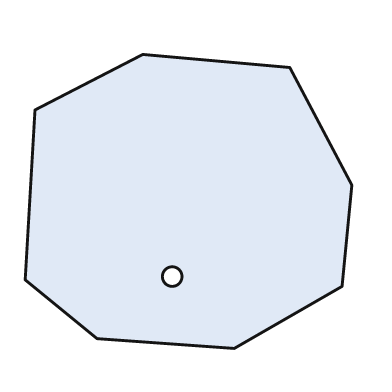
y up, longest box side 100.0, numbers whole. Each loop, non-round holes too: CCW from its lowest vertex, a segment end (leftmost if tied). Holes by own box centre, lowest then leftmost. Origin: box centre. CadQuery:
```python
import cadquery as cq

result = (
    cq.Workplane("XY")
    .moveTo(14.0, -45.0)
    .lineTo(47.0, -26.0)
    .lineTo(50.0, 5.0)
    .lineTo(31.0, 41.0)
    .lineTo(-14.0, 45.0)
    .lineTo(-47.0, 28.0)
    .lineTo(-50.0, -24.0)
    .lineTo(-28.0, -42.0)
    .close()
    .moveTo(-5.0, -23.0)
    .circle(3.0)
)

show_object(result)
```